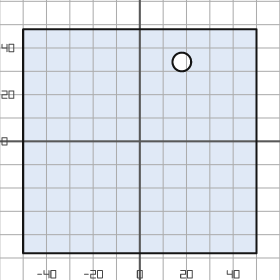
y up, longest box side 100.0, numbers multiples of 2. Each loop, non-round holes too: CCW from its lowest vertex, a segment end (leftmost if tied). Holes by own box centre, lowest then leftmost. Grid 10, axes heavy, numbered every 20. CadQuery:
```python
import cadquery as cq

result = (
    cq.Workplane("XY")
    .moveTo(-50.0, -48.0)
    .lineTo(50.0, -48.0)
    .lineTo(50.0, 48.0)
    .lineTo(-50.0, 48.0)
    .close()
    .moveTo(18.0, 34.0)
    .circle(4.0)
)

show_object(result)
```